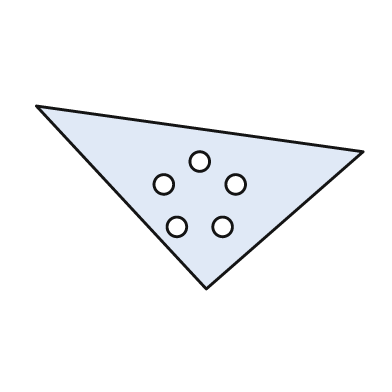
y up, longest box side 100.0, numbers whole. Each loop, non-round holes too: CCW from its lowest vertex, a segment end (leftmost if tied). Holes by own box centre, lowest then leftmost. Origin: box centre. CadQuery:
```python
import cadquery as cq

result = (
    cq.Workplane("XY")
    .moveTo(2.0, -28.0)
    .lineTo(50.0, 14.0)
    .lineTo(-50.0, 28.0)
    .close()
    .moveTo(-7.0, -9.0)
    .circle(3.0)
    .moveTo(7.0, -9.0)
    .circle(3.0)
    .moveTo(-11.0, 4.0)
    .circle(3.0)
    .moveTo(11.0, 4.0)
    .circle(3.0)
    .moveTo(0.0, 11.0)
    .circle(3.0)
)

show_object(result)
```